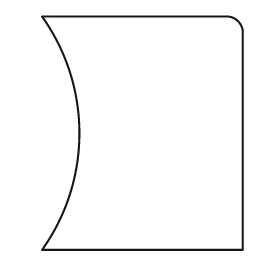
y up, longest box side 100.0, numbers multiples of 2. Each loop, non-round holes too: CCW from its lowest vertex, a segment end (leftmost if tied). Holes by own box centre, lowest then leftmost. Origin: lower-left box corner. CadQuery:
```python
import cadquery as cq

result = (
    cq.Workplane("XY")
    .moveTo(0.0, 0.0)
    .lineTo(86.0, 0.0)
    .lineTo(86.0, 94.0)
    .threePointArc((84.0, 98.0), (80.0, 100.0))
    .lineTo(0.0, 100.0)
    .threePointArc((16.0, 50.0), (0.0, 0.0))
    .close()
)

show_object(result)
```